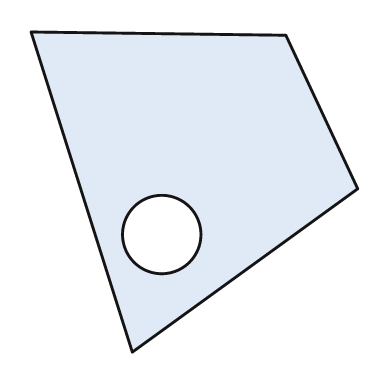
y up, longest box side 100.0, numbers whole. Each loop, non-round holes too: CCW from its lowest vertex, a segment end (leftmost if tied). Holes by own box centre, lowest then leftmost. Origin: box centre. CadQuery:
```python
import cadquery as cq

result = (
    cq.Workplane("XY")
    .moveTo(-19.0, -49.0)
    .lineTo(50.0, 1.0)
    .lineTo(28.0, 48.0)
    .lineTo(-50.0, 49.0)
    .close()
    .moveTo(-10.0, -13.0)
    .circle(12.0)
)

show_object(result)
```